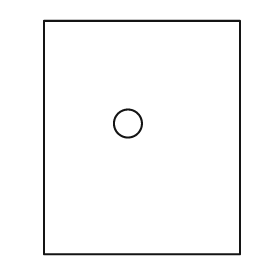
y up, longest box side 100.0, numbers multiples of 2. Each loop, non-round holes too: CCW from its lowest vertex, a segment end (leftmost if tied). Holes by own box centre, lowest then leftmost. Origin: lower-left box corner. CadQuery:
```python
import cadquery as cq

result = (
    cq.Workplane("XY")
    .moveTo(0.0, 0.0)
    .lineTo(84.0, 0.0)
    .lineTo(84.0, 100.0)
    .lineTo(0.0, 100.0)
    .close()
    .moveTo(36.0, 56.0)
    .circle(6.0)
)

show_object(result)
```